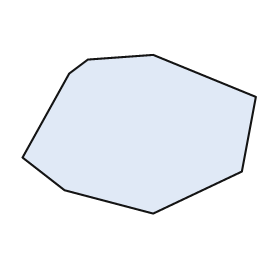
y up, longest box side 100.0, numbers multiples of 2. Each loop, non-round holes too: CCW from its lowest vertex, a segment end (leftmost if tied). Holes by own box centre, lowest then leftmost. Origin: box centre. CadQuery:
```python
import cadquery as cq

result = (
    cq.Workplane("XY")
    .moveTo(6.0, -34.0)
    .lineTo(44.0, -16.0)
    .lineTo(50.0, 16.0)
    .lineTo(6.0, 34.0)
    .lineTo(-22.0, 32.0)
    .lineTo(-30.0, 26.0)
    .lineTo(-50.0, -10.0)
    .lineTo(-32.0, -24.0)
    .close()
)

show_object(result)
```